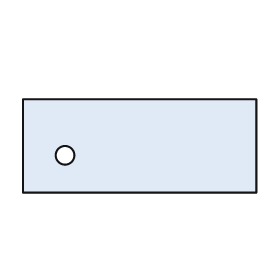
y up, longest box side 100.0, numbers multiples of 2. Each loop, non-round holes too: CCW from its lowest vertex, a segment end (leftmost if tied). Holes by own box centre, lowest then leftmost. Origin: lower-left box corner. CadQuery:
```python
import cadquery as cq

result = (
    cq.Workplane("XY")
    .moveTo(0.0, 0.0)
    .lineTo(100.0, 0.0)
    .lineTo(100.0, 40.0)
    .lineTo(0.0, 40.0)
    .close()
    .moveTo(18.0, 16.0)
    .circle(4.0)
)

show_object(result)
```